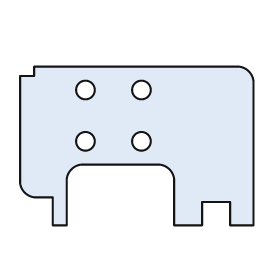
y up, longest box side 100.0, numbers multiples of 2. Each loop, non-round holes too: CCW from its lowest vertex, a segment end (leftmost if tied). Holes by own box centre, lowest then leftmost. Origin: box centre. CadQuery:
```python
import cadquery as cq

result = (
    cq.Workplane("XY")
    .moveTo(-36.0, -34.0)
    .lineTo(-30.0, -34.0)
    .lineTo(-30.0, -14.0)
    .threePointArc((-28.0, -10.0), (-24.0, -8.0))
    .lineTo(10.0, -8.0)
    .threePointArc((14.0, -10.0), (16.0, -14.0))
    .lineTo(16.0, -34.0)
    .lineTo(28.0, -34.0)
    .lineTo(28.0, -24.0)
    .lineTo(40.0, -24.0)
    .lineTo(40.0, -34.0)
    .lineTo(50.0, -34.0)
    .lineTo(50.0, 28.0)
    .threePointArc((48.0, 32.0), (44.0, 34.0))
    .lineTo(-44.0, 34.0)
    .lineTo(-44.0, 30.0)
    .lineTo(-50.0, 30.0)
    .lineTo(-50.0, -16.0)
    .threePointArc((-48.0, -20.0), (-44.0, -22.0))
    .lineTo(-36.0, -22.0)
    .close()
    .moveTo(-22.0, 2.0)
    .circle(4.0)
    .moveTo(2.0, 2.0)
    .circle(4.0)
    .moveTo(-22.0, 24.0)
    .circle(4.0)
    .moveTo(2.0, 24.0)
    .circle(4.0)
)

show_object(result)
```